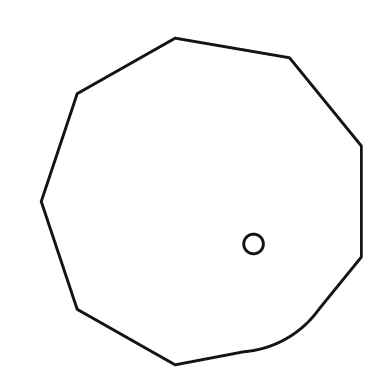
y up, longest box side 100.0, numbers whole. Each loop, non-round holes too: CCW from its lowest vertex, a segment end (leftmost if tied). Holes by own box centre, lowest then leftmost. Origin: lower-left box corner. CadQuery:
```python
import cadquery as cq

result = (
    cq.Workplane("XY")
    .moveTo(41.0, 0.0)
    .lineTo(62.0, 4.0)
    .threePointArc((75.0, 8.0), (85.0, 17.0))
    .lineTo(98.0, 33.0)
    .lineTo(98.0, 67.0)
    .lineTo(76.0, 94.0)
    .lineTo(41.0, 100.0)
    .lineTo(11.0, 83.0)
    .lineTo(0.0, 50.0)
    .lineTo(11.0, 17.0)
    .close()
    .moveTo(65.0, 37.0)
    .circle(3.0)
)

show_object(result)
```